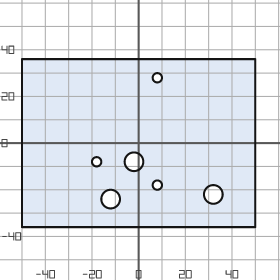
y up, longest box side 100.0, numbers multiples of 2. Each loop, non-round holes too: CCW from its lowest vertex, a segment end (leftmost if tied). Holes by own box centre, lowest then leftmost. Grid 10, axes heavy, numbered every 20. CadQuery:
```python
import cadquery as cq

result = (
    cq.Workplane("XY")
    .moveTo(-50.0, -36.0)
    .lineTo(50.0, -36.0)
    .lineTo(50.0, 36.0)
    .lineTo(-50.0, 36.0)
    .close()
    .moveTo(-12.0, -24.0)
    .circle(4.0)
    .moveTo(32.0, -22.0)
    .circle(4.0)
    .moveTo(8.0, -18.0)
    .circle(2.0)
    .moveTo(-18.0, -8.0)
    .circle(2.0)
    .moveTo(-2.0, -8.0)
    .circle(4.0)
    .moveTo(8.0, 28.0)
    .circle(2.0)
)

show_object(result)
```